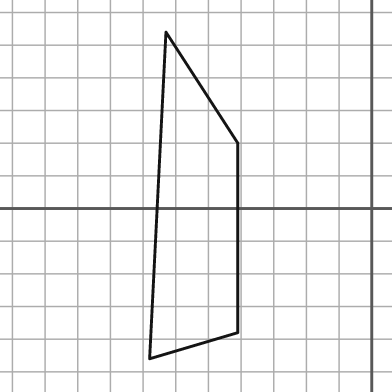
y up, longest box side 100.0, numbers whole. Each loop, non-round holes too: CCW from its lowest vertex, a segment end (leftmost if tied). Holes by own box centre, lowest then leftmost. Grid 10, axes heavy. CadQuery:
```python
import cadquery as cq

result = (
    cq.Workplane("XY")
    .moveTo(-68.0, -46.0)
    .lineTo(-41.0, -38.0)
    .lineTo(-41.0, 20.0)
    .lineTo(-63.0, 54.0)
    .close()
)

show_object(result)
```